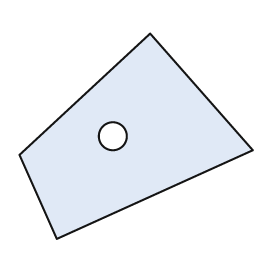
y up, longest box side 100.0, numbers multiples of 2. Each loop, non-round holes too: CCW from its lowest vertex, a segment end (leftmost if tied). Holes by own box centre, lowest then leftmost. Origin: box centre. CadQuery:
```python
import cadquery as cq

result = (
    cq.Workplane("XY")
    .moveTo(-34.0, -44.0)
    .lineTo(50.0, -6.0)
    .lineTo(6.0, 44.0)
    .lineTo(-50.0, -8.0)
    .close()
    .moveTo(-10.0, 0.0)
    .circle(6.0)
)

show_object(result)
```